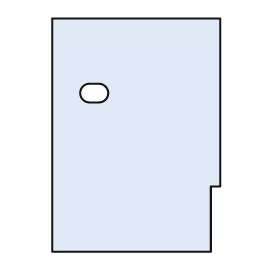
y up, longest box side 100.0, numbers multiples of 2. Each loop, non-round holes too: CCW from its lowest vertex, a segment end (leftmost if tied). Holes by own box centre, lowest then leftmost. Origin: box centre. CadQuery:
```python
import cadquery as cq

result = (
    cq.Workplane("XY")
    .moveTo(-36.0, -50.0)
    .lineTo(32.0, -50.0)
    .lineTo(32.0, -22.0)
    .lineTo(36.0, -22.0)
    .lineTo(36.0, 50.0)
    .lineTo(-36.0, 50.0)
    .close()
    .moveTo(-20.0, 14.0)
    .lineTo(-16.0, 14.0)
    .threePointArc((-12.0, 18.0), (-16.0, 22.0))
    .lineTo(-20.0, 22.0)
    .threePointArc((-24.0, 18.0), (-20.0, 14.0))
    .close()
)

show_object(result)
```